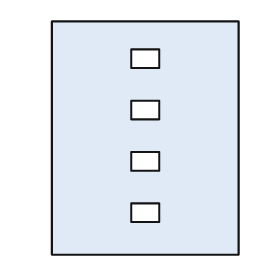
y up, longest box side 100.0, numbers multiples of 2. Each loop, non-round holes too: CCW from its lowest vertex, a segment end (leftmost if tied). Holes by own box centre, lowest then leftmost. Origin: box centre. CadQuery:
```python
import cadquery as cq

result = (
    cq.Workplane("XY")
    .moveTo(-40.0, -50.0)
    .lineTo(40.0, -50.0)
    .lineTo(40.0, 50.0)
    .lineTo(-40.0, 50.0)
    .close()
    .moveTo(-6.0, -36.0)
    .lineTo(6.0, -36.0)
    .lineTo(6.0, -28.0)
    .lineTo(-6.0, -28.0)
    .close()
    .moveTo(-6.0, -14.0)
    .lineTo(6.0, -14.0)
    .lineTo(6.0, -6.0)
    .lineTo(-6.0, -6.0)
    .close()
    .moveTo(-6.0, 8.0)
    .lineTo(6.0, 8.0)
    .lineTo(6.0, 16.0)
    .lineTo(-6.0, 16.0)
    .close()
    .moveTo(-6.0, 30.0)
    .lineTo(6.0, 30.0)
    .lineTo(6.0, 38.0)
    .lineTo(-6.0, 38.0)
    .close()
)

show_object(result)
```